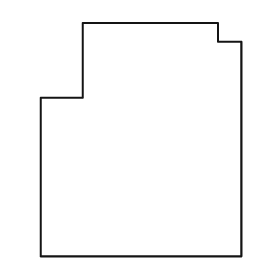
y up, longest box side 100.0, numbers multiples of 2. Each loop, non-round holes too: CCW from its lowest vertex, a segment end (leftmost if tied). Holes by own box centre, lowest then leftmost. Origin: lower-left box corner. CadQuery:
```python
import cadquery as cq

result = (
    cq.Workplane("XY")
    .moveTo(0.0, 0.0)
    .lineTo(86.0, 0.0)
    .lineTo(86.0, 92.0)
    .lineTo(76.0, 92.0)
    .lineTo(76.0, 100.0)
    .lineTo(18.0, 100.0)
    .lineTo(18.0, 68.0)
    .lineTo(0.0, 68.0)
    .close()
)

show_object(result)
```